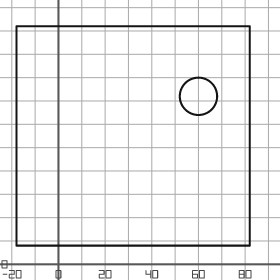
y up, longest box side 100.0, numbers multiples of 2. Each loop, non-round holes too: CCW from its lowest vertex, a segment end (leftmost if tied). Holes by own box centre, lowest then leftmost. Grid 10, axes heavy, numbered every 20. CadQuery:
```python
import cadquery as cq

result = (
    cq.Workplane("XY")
    .moveTo(-18.0, 8.0)
    .lineTo(82.0, 8.0)
    .lineTo(82.0, 102.0)
    .lineTo(-18.0, 102.0)
    .close()
    .moveTo(60.0, 72.0)
    .circle(8.0)
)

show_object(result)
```